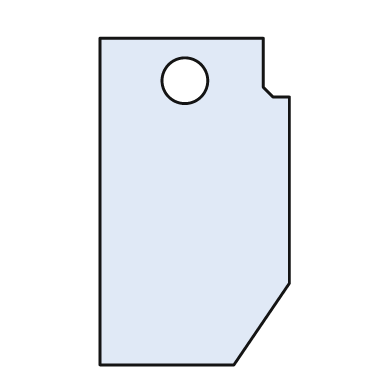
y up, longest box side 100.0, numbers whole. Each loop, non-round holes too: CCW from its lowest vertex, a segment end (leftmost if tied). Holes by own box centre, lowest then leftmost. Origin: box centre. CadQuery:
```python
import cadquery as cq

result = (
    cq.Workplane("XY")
    .moveTo(-29.0, -50.0)
    .lineTo(12.0, -50.0)
    .lineTo(29.0, -25.0)
    .lineTo(29.0, 32.0)
    .lineTo(24.0, 32.0)
    .lineTo(21.0, 35.0)
    .lineTo(21.0, 50.0)
    .lineTo(-29.0, 50.0)
    .close()
    .moveTo(-3.0, 37.0)
    .circle(7.0)
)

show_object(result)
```